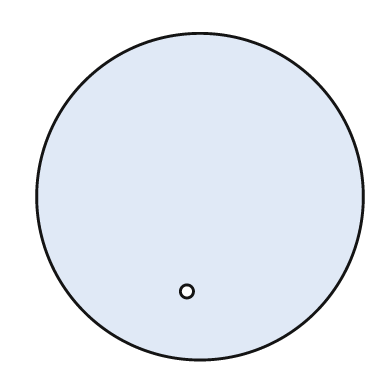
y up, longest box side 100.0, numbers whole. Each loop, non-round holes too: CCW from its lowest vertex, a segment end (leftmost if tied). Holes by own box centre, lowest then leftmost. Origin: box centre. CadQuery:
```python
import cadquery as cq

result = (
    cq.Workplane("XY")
    .moveTo(0.0, 0.0)
    .circle(50.0)
    .moveTo(-4.0, -29.0)
    .circle(2.0)
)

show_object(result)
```